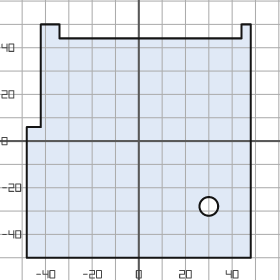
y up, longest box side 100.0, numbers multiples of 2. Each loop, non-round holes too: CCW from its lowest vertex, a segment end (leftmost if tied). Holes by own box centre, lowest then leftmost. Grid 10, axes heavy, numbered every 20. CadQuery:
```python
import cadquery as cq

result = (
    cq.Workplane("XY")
    .moveTo(-48.0, -50.0)
    .lineTo(48.0, -50.0)
    .lineTo(48.0, 50.0)
    .lineTo(44.0, 50.0)
    .lineTo(44.0, 44.0)
    .lineTo(-34.0, 44.0)
    .lineTo(-34.0, 50.0)
    .lineTo(-42.0, 50.0)
    .lineTo(-42.0, 6.0)
    .lineTo(-48.0, 6.0)
    .close()
    .moveTo(30.0, -28.0)
    .circle(4.0)
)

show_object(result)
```